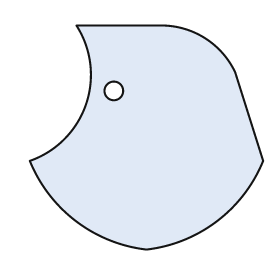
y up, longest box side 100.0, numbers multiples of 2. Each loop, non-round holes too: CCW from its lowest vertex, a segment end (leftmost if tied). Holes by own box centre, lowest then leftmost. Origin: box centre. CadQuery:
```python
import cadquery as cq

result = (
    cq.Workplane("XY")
    .moveTo(0.0, -48.0)
    .threePointArc((30.0, -36.0), (50.0, -10.0))
    .lineTo(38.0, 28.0)
    .threePointArc((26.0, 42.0), (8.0, 48.0))
    .lineTo(-30.0, 48.0)
    .threePointArc((-26.0, 14.0), (-50.0, -10.0))
    .threePointArc((-30.0, -36.0), (0.0, -48.0))
    .close()
    .moveTo(-14.0, 20.0)
    .circle(4.0)
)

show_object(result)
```